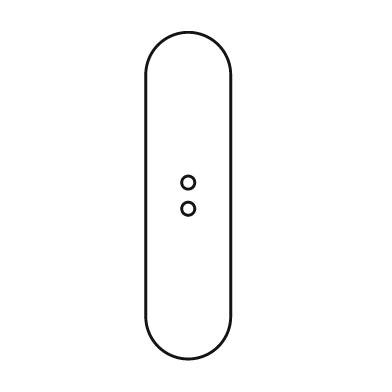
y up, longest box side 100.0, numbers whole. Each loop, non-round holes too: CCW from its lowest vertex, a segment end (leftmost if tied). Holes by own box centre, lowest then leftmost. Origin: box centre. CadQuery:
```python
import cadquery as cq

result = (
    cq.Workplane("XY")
    .moveTo(-13.0, -37.0)
    .threePointArc((0.0, -50.0), (13.0, -37.0))
    .lineTo(13.0, 37.0)
    .threePointArc((0.0, 50.0), (-13.0, 37.0))
    .close()
    .moveTo(0.0, -4.0)
    .circle(2.0)
    .moveTo(0.0, 4.0)
    .circle(2.0)
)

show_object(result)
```